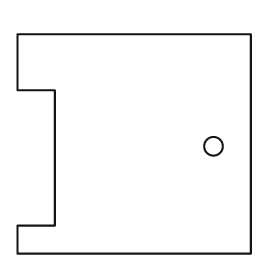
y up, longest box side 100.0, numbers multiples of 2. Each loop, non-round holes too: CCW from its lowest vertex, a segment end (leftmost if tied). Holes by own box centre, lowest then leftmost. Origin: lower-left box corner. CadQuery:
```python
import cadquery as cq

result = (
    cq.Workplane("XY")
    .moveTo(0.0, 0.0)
    .lineTo(100.0, 0.0)
    .lineTo(100.0, 94.0)
    .lineTo(0.0, 94.0)
    .lineTo(0.0, 70.0)
    .lineTo(16.0, 70.0)
    .lineTo(16.0, 12.0)
    .lineTo(0.0, 12.0)
    .close()
    .moveTo(84.0, 46.0)
    .circle(4.0)
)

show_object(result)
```